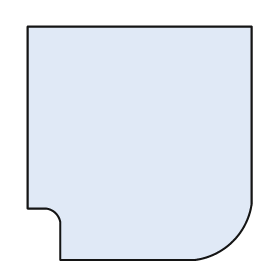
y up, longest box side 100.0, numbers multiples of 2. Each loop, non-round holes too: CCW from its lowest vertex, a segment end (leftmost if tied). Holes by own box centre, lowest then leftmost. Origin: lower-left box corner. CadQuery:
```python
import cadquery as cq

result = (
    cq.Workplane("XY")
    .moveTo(14.0, 0.0)
    .lineTo(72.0, 0.0)
    .threePointArc((88.0, 8.0), (96.0, 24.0))
    .lineTo(96.0, 100.0)
    .lineTo(0.0, 100.0)
    .lineTo(0.0, 22.0)
    .lineTo(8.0, 22.0)
    .threePointArc((12.0, 20.0), (14.0, 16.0))
    .close()
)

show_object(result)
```